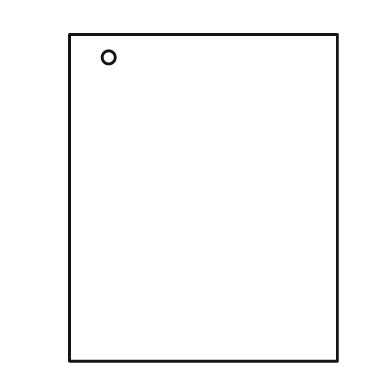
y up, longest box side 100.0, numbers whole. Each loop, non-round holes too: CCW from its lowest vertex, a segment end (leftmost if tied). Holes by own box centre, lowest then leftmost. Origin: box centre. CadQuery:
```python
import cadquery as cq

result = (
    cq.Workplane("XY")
    .moveTo(-41.0, -50.0)
    .lineTo(41.0, -50.0)
    .lineTo(41.0, 50.0)
    .lineTo(-41.0, 50.0)
    .close()
    .moveTo(-29.0, 43.0)
    .circle(2.0)
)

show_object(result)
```